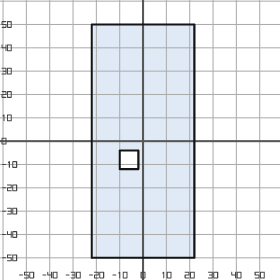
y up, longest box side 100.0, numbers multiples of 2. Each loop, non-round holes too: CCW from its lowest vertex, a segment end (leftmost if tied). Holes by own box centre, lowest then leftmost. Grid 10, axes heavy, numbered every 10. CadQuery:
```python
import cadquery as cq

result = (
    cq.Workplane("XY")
    .moveTo(-22.0, -50.0)
    .lineTo(22.0, -50.0)
    .lineTo(22.0, 50.0)
    .lineTo(-22.0, 50.0)
    .close()
    .moveTo(-10.0, -12.0)
    .lineTo(-2.0, -12.0)
    .lineTo(-2.0, -4.0)
    .lineTo(-10.0, -4.0)
    .close()
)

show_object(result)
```